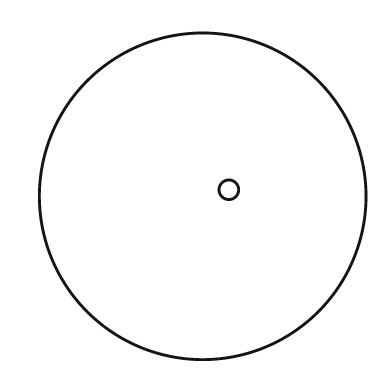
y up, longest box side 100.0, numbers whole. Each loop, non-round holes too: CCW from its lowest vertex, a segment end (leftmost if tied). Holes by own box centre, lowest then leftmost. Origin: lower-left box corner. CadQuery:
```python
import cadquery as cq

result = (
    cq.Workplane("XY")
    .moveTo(50.0, 50.0)
    .circle(50.0)
    .moveTo(58.0, 52.0)
    .circle(3.0)
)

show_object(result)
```